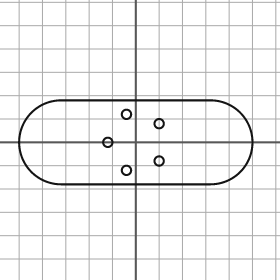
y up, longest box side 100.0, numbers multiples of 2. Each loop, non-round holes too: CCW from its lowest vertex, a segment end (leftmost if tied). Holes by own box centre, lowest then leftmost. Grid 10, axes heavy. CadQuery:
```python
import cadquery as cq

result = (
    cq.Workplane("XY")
    .moveTo(-32.0, -18.0)
    .lineTo(32.0, -18.0)
    .threePointArc((50.0, 0.0), (32.0, 18.0))
    .lineTo(-32.0, 18.0)
    .threePointArc((-50.0, 0.0), (-32.0, -18.0))
    .close()
    .moveTo(-4.0, -12.0)
    .circle(2.0)
    .moveTo(10.0, -8.0)
    .circle(2.0)
    .moveTo(-12.0, 0.0)
    .circle(2.0)
    .moveTo(10.0, 8.0)
    .circle(2.0)
    .moveTo(-4.0, 12.0)
    .circle(2.0)
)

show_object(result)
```